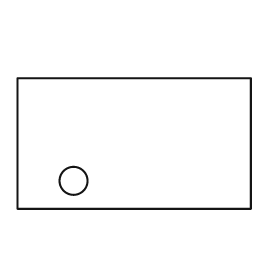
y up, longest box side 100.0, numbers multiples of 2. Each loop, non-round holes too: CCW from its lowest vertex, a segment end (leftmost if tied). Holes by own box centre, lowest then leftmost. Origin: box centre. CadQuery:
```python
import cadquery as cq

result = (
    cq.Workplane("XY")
    .moveTo(-50.0, -28.0)
    .lineTo(50.0, -28.0)
    .lineTo(50.0, 28.0)
    .lineTo(-50.0, 28.0)
    .close()
    .moveTo(-26.0, -16.0)
    .circle(6.0)
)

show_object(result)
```